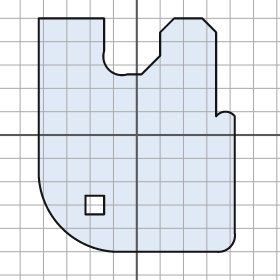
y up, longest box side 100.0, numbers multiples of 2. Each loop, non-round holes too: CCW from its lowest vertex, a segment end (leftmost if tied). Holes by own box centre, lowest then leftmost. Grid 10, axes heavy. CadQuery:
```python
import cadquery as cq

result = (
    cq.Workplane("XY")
    .moveTo(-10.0, -50.0)
    .lineTo(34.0, -50.0)
    .threePointArc((40.0, -48.0), (42.0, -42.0))
    .lineTo(42.0, 8.0)
    .threePointArc((38.0, 10.0), (34.0, 8.0))
    .lineTo(34.0, 44.0)
    .lineTo(28.0, 50.0)
    .lineTo(16.0, 50.0)
    .lineTo(10.0, 44.0)
    .lineTo(10.0, 34.0)
    .lineTo(2.0, 26.0)
    .lineTo(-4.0, 26.0)
    .threePointArc((-12.0, 28.0), (-14.0, 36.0))
    .lineTo(-14.0, 50.0)
    .lineTo(-42.0, 50.0)
    .lineTo(-42.0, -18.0)
    .threePointArc((-32.0, -40.0), (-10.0, -50.0))
    .close()
    .moveTo(-22.0, -34.0)
    .lineTo(-14.0, -34.0)
    .lineTo(-14.0, -26.0)
    .lineTo(-22.0, -26.0)
    .close()
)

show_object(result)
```